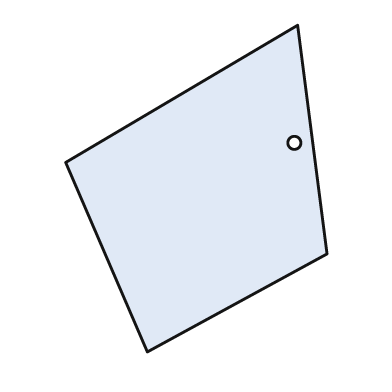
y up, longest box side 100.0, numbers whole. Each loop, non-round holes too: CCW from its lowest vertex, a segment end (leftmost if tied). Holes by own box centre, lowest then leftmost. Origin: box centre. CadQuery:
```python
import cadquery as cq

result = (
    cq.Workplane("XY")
    .moveTo(-15.0, -50.0)
    .lineTo(40.0, -20.0)
    .lineTo(31.0, 50.0)
    .lineTo(-40.0, 8.0)
    .close()
    .moveTo(30.0, 14.0)
    .circle(2.0)
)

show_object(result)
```